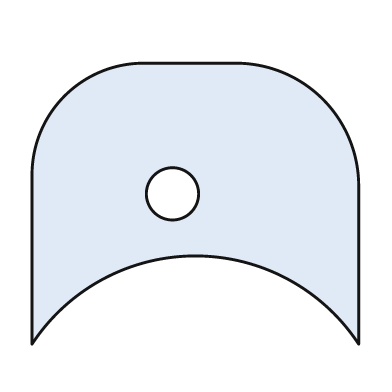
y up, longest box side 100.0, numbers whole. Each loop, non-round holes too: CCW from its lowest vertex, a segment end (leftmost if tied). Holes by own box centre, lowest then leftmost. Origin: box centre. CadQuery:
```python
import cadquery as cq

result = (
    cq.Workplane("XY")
    .moveTo(-50.0, -43.0)
    .threePointArc((0.0, -16.0), (50.0, -43.0))
    .lineTo(50.0, 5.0)
    .threePointArc((39.0, 32.0), (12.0, 43.0))
    .lineTo(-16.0, 43.0)
    .threePointArc((-40.0, 33.0), (-50.0, 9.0))
    .close()
    .moveTo(-7.0, 3.0)
    .circle(8.0)
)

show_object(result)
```